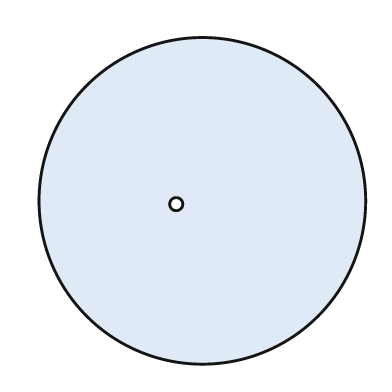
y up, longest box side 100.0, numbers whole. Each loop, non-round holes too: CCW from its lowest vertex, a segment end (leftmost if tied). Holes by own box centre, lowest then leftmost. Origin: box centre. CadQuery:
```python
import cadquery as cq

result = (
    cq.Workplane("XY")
    .moveTo(0.0, 0.0)
    .circle(50.0)
    .moveTo(-8.0, -1.0)
    .circle(2.0)
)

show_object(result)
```